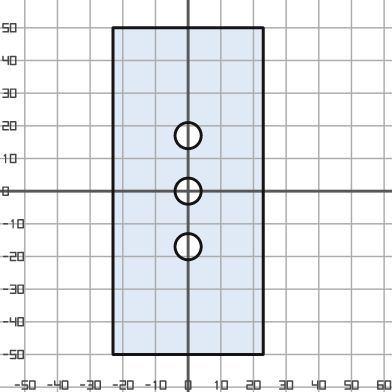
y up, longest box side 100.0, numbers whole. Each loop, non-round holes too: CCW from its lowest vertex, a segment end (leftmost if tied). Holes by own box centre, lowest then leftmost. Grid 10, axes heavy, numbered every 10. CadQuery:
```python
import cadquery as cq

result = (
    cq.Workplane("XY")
    .moveTo(-23.0, -50.0)
    .lineTo(23.0, -50.0)
    .lineTo(23.0, 50.0)
    .lineTo(-23.0, 50.0)
    .close()
    .moveTo(0.0, -17.0)
    .circle(4.0)
    .moveTo(0.0, 0.0)
    .circle(4.0)
    .moveTo(0.0, 17.0)
    .circle(4.0)
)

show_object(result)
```